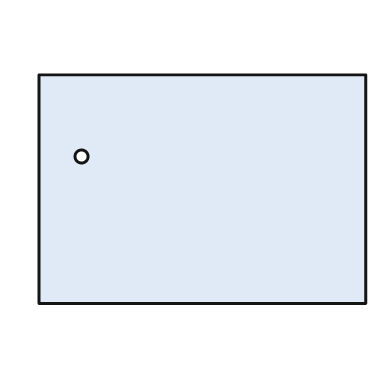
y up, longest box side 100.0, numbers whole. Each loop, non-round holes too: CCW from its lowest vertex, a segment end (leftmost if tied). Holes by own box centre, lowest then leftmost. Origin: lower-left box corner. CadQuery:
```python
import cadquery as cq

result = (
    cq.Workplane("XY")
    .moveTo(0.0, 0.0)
    .lineTo(100.0, 0.0)
    .lineTo(100.0, 70.0)
    .lineTo(0.0, 70.0)
    .close()
    .moveTo(13.0, 45.0)
    .circle(2.0)
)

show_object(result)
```